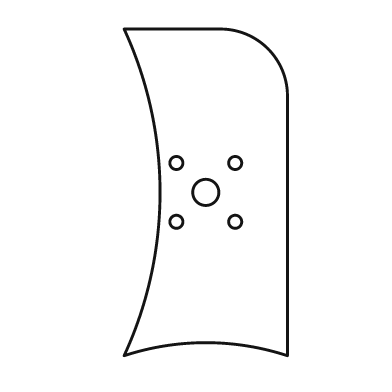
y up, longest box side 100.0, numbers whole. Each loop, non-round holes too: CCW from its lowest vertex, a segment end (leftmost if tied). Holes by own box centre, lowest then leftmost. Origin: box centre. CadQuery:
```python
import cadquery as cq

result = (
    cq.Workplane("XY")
    .moveTo(-25.0, -50.0)
    .threePointArc((0.0, -46.0), (25.0, -50.0))
    .lineTo(25.0, 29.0)
    .threePointArc((19.0, 44.0), (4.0, 50.0))
    .lineTo(-25.0, 50.0)
    .threePointArc((-14.0, 0.0), (-25.0, -50.0))
    .close()
    .moveTo(-9.0, -9.0)
    .circle(2.0)
    .moveTo(9.0, -9.0)
    .circle(2.0)
    .moveTo(0.0, 0.0)
    .circle(4.0)
    .moveTo(-9.0, 9.0)
    .circle(2.0)
    .moveTo(9.0, 9.0)
    .circle(2.0)
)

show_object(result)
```